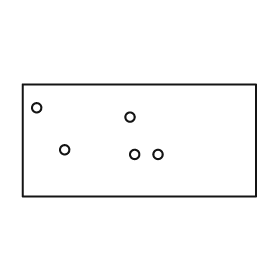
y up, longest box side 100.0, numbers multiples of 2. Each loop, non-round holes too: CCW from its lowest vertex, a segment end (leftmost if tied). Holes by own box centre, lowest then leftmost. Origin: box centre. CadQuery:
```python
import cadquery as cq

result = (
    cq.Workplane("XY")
    .moveTo(-50.0, -24.0)
    .lineTo(50.0, -24.0)
    .lineTo(50.0, 24.0)
    .lineTo(-50.0, 24.0)
    .close()
    .moveTo(-2.0, -6.0)
    .circle(2.0)
    .moveTo(8.0, -6.0)
    .circle(2.0)
    .moveTo(-32.0, -4.0)
    .circle(2.0)
    .moveTo(-4.0, 10.0)
    .circle(2.0)
    .moveTo(-44.0, 14.0)
    .circle(2.0)
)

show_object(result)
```